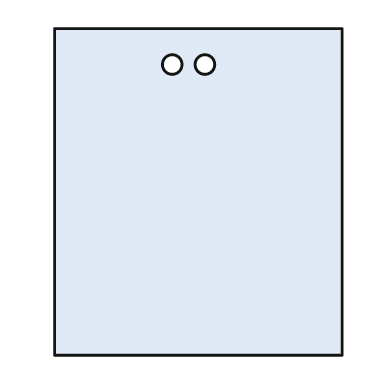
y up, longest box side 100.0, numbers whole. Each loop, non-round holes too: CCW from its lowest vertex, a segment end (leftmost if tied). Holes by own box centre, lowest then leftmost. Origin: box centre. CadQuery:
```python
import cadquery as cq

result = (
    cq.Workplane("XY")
    .moveTo(-44.0, -50.0)
    .lineTo(44.0, -50.0)
    .lineTo(44.0, 50.0)
    .lineTo(-44.0, 50.0)
    .close()
    .moveTo(-8.0, 39.0)
    .circle(3.0)
    .moveTo(2.0, 39.0)
    .circle(3.0)
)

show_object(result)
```